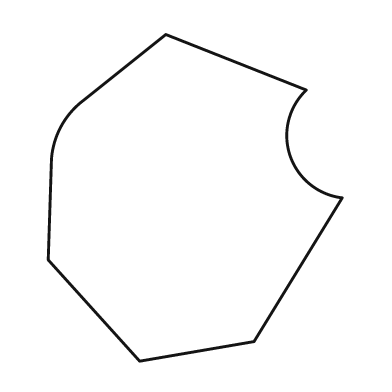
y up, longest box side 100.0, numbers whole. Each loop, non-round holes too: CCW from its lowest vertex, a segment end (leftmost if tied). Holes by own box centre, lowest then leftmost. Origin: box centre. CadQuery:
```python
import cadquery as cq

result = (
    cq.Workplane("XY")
    .moveTo(-17.0, -50.0)
    .lineTo(18.0, -44.0)
    .lineTo(45.0, 0.0)
    .threePointArc((29.0, 13.0), (34.0, 33.0))
    .lineTo(-9.0, 50.0)
    .lineTo(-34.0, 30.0)
    .threePointArc((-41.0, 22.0), (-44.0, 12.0))
    .lineTo(-45.0, -19.0)
    .close()
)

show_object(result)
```